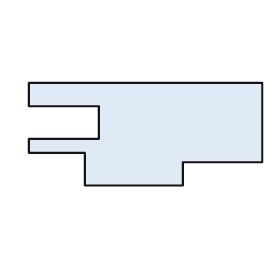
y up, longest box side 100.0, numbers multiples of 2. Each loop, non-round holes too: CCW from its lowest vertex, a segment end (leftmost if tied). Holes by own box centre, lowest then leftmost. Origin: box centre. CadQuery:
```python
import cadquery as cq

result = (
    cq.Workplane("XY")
    .moveTo(-26.0, -22.0)
    .lineTo(16.0, -22.0)
    .lineTo(16.0, -12.0)
    .lineTo(50.0, -12.0)
    .lineTo(50.0, 22.0)
    .lineTo(-50.0, 22.0)
    .lineTo(-50.0, 12.0)
    .lineTo(-20.0, 12.0)
    .lineTo(-20.0, -2.0)
    .lineTo(-50.0, -2.0)
    .lineTo(-50.0, -8.0)
    .lineTo(-26.0, -8.0)
    .close()
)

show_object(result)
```